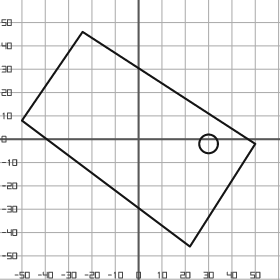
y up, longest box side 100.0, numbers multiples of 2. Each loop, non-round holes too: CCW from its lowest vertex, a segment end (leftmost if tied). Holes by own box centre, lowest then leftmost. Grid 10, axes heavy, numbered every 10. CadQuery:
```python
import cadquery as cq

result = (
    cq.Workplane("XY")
    .moveTo(22.0, -46.0)
    .lineTo(50.0, -2.0)
    .lineTo(-24.0, 46.0)
    .lineTo(-50.0, 8.0)
    .close()
    .moveTo(30.0, -2.0)
    .circle(4.0)
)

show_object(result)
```